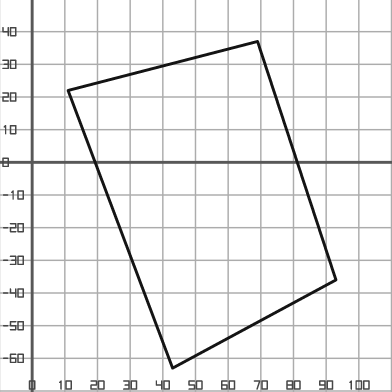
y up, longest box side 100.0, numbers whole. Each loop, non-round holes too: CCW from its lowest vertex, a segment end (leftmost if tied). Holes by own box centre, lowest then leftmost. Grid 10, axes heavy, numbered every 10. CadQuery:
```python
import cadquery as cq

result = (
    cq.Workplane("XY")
    .moveTo(43.0, -63.0)
    .lineTo(93.0, -36.0)
    .lineTo(69.0, 37.0)
    .lineTo(11.0, 22.0)
    .close()
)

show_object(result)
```